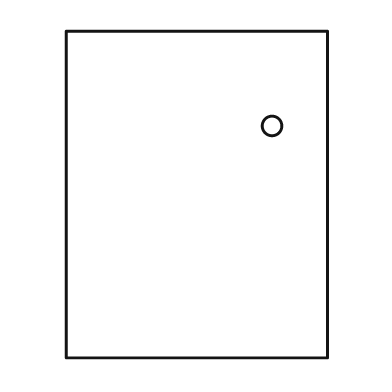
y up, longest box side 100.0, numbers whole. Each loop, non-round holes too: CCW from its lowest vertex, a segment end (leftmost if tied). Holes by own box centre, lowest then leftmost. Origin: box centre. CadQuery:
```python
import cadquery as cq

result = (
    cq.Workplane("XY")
    .moveTo(-40.0, -50.0)
    .lineTo(40.0, -50.0)
    .lineTo(40.0, 50.0)
    .lineTo(-40.0, 50.0)
    .close()
    .moveTo(23.0, 21.0)
    .circle(3.0)
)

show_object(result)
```